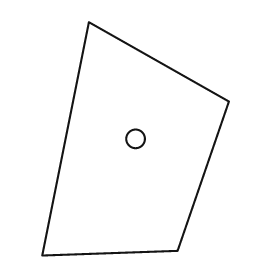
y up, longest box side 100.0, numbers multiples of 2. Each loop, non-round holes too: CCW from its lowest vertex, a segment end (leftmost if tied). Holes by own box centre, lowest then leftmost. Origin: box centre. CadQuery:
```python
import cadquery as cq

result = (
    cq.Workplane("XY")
    .moveTo(-40.0, -50.0)
    .lineTo(18.0, -48.0)
    .lineTo(40.0, 16.0)
    .lineTo(-20.0, 50.0)
    .close()
    .moveTo(0.0, 0.0)
    .circle(4.0)
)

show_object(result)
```